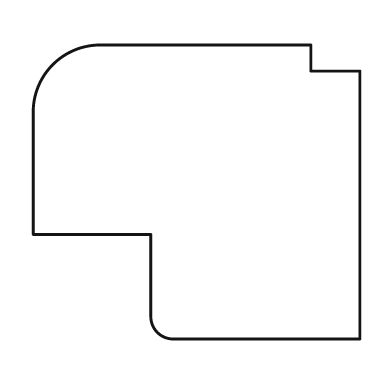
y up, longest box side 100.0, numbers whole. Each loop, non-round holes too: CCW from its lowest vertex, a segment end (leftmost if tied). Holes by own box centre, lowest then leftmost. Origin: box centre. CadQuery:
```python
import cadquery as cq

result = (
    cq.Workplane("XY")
    .moveTo(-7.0, -45.0)
    .lineTo(50.0, -45.0)
    .lineTo(50.0, 37.0)
    .lineTo(35.0, 37.0)
    .lineTo(35.0, 45.0)
    .lineTo(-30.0, 45.0)
    .threePointArc((-44.0, 39.0), (-50.0, 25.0))
    .lineTo(-50.0, -13.0)
    .lineTo(-14.0, -13.0)
    .lineTo(-14.0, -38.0)
    .threePointArc((-12.0, -43.0), (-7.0, -45.0))
    .close()
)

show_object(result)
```